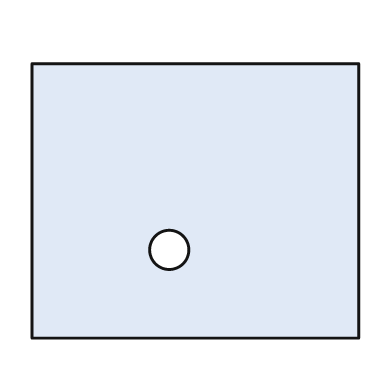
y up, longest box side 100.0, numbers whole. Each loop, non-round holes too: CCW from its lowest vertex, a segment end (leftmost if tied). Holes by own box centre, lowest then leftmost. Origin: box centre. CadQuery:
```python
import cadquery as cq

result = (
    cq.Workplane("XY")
    .moveTo(-50.0, -42.0)
    .lineTo(50.0, -42.0)
    .lineTo(50.0, 42.0)
    .lineTo(-50.0, 42.0)
    .close()
    .moveTo(-8.0, -15.0)
    .circle(6.0)
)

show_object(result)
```